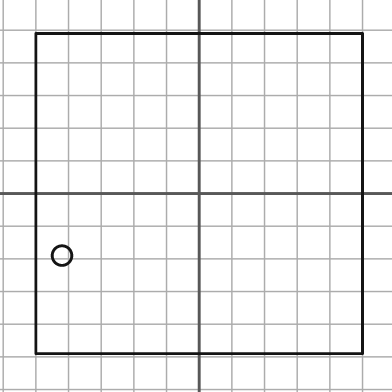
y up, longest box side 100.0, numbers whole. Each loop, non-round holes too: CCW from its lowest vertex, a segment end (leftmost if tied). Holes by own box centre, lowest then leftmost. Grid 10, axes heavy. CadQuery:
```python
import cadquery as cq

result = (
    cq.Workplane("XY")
    .moveTo(-50.0, -49.0)
    .lineTo(50.0, -49.0)
    .lineTo(50.0, 49.0)
    .lineTo(-50.0, 49.0)
    .close()
    .moveTo(-42.0, -19.0)
    .circle(3.0)
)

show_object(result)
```